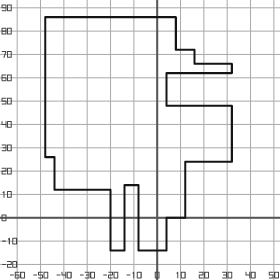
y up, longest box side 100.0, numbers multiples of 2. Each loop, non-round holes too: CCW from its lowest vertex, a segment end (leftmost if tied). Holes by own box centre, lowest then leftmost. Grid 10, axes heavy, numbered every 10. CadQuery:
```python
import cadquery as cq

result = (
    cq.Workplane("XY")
    .moveTo(-20.0, -14.0)
    .lineTo(-14.0, -14.0)
    .lineTo(-14.0, 14.0)
    .lineTo(-8.0, 14.0)
    .lineTo(-8.0, -14.0)
    .lineTo(4.0, -14.0)
    .lineTo(4.0, 0.0)
    .lineTo(12.0, 0.0)
    .lineTo(12.0, 24.0)
    .lineTo(32.0, 24.0)
    .lineTo(32.0, 48.0)
    .lineTo(4.0, 48.0)
    .lineTo(4.0, 62.0)
    .lineTo(32.0, 62.0)
    .lineTo(32.0, 66.0)
    .lineTo(16.0, 66.0)
    .lineTo(16.0, 72.0)
    .lineTo(8.0, 72.0)
    .lineTo(8.0, 86.0)
    .lineTo(-48.0, 86.0)
    .lineTo(-48.0, 26.0)
    .lineTo(-44.0, 26.0)
    .lineTo(-44.0, 12.0)
    .lineTo(-20.0, 12.0)
    .close()
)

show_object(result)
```